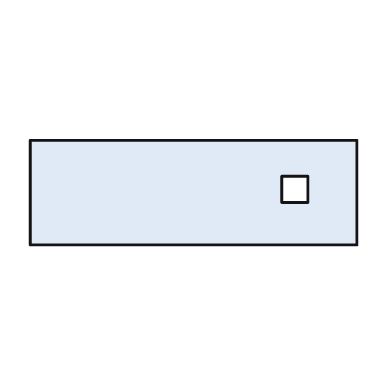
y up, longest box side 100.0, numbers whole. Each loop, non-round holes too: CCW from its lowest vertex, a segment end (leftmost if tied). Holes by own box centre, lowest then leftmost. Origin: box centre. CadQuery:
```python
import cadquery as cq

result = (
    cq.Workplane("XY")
    .moveTo(-50.0, -16.0)
    .lineTo(50.0, -16.0)
    .lineTo(50.0, 16.0)
    .lineTo(-50.0, 16.0)
    .close()
    .moveTo(27.0, -3.0)
    .lineTo(35.0, -3.0)
    .lineTo(35.0, 5.0)
    .lineTo(27.0, 5.0)
    .close()
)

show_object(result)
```